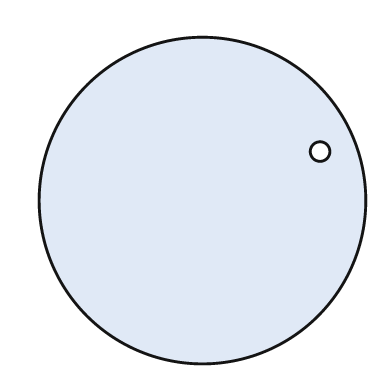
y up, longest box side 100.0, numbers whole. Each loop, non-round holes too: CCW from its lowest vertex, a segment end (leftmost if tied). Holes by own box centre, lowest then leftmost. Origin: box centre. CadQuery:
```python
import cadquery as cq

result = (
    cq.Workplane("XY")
    .moveTo(0.0, 0.0)
    .circle(50.0)
    .moveTo(36.0, 15.0)
    .circle(3.0)
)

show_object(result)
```